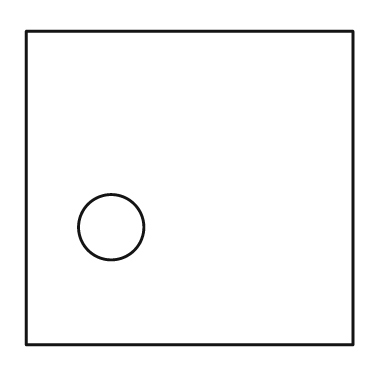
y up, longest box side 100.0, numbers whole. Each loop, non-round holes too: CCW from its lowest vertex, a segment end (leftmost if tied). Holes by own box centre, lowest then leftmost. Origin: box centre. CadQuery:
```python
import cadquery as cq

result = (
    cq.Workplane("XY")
    .moveTo(-50.0, -48.0)
    .lineTo(50.0, -48.0)
    .lineTo(50.0, 48.0)
    .lineTo(-50.0, 48.0)
    .close()
    .moveTo(-24.0, -12.0)
    .circle(10.0)
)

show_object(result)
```